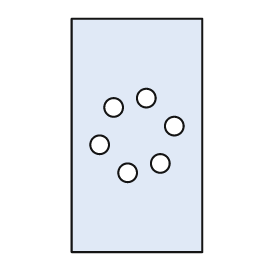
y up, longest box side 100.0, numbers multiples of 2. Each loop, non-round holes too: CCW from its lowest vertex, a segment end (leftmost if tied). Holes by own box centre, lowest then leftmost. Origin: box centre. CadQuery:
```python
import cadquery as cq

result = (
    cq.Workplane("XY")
    .moveTo(-28.0, -50.0)
    .lineTo(28.0, -50.0)
    .lineTo(28.0, 50.0)
    .lineTo(-28.0, 50.0)
    .close()
    .moveTo(-4.0, -16.0)
    .circle(4.0)
    .moveTo(10.0, -12.0)
    .circle(4.0)
    .moveTo(-16.0, -4.0)
    .circle(4.0)
    .moveTo(16.0, 4.0)
    .circle(4.0)
    .moveTo(-10.0, 12.0)
    .circle(4.0)
    .moveTo(4.0, 16.0)
    .circle(4.0)
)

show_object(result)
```